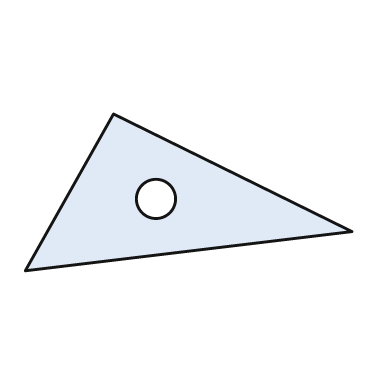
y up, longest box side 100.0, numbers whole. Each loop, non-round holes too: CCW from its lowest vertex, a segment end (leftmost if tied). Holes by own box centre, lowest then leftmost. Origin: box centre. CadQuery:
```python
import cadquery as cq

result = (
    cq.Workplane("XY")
    .moveTo(-50.0, -24.0)
    .lineTo(50.0, -12.0)
    .lineTo(-23.0, 24.0)
    .close()
    .moveTo(-10.0, -2.0)
    .circle(6.0)
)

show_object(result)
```